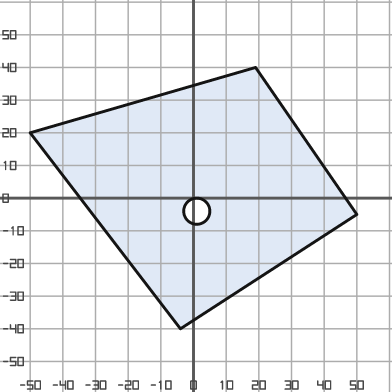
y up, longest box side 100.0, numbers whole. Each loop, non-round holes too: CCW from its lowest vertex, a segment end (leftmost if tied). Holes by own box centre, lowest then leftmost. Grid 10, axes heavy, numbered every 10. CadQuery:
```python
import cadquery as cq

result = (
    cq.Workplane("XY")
    .moveTo(-4.0, -40.0)
    .lineTo(50.0, -5.0)
    .lineTo(19.0, 40.0)
    .lineTo(-50.0, 20.0)
    .close()
    .moveTo(1.0, -4.0)
    .circle(4.0)
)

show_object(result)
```